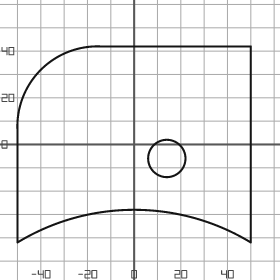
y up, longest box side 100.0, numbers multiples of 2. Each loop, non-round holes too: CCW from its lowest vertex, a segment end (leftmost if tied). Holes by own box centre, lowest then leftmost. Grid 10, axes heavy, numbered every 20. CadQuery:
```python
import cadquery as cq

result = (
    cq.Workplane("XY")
    .moveTo(-50.0, -42.0)
    .threePointArc((0.0, -28.0), (50.0, -42.0))
    .lineTo(50.0, 42.0)
    .lineTo(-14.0, 42.0)
    .threePointArc((-40.0, 32.0), (-50.0, 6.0))
    .close()
    .moveTo(14.0, -6.0)
    .circle(8.0)
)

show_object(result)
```